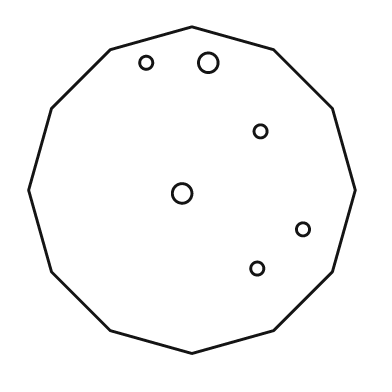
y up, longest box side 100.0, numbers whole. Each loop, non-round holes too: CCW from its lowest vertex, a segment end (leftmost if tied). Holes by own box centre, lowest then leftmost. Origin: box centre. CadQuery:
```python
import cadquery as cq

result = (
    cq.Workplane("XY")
    .moveTo(0.0, -50.0)
    .lineTo(25.0, -43.0)
    .lineTo(43.0, -25.0)
    .lineTo(50.0, 0.0)
    .lineTo(43.0, 25.0)
    .lineTo(25.0, 43.0)
    .lineTo(0.0, 50.0)
    .lineTo(-25.0, 43.0)
    .lineTo(-43.0, 25.0)
    .lineTo(-50.0, 0.0)
    .lineTo(-43.0, -25.0)
    .lineTo(-25.0, -43.0)
    .close()
    .moveTo(20.0, -24.0)
    .circle(2.0)
    .moveTo(34.0, -12.0)
    .circle(2.0)
    .moveTo(-3.0, -1.0)
    .circle(3.0)
    .moveTo(21.0, 18.0)
    .circle(2.0)
    .moveTo(-14.0, 39.0)
    .circle(2.0)
    .moveTo(5.0, 39.0)
    .circle(3.0)
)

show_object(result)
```